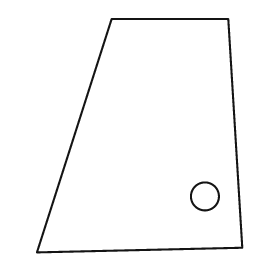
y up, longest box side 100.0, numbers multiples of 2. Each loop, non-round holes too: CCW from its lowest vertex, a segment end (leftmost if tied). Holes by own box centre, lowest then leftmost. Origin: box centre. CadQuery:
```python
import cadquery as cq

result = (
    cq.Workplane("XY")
    .moveTo(-44.0, -50.0)
    .lineTo(44.0, -48.0)
    .lineTo(38.0, 50.0)
    .lineTo(-12.0, 50.0)
    .close()
    .moveTo(28.0, -26.0)
    .circle(6.0)
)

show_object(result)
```